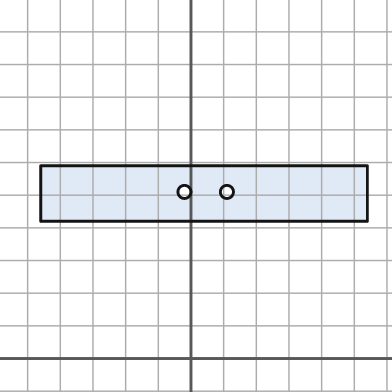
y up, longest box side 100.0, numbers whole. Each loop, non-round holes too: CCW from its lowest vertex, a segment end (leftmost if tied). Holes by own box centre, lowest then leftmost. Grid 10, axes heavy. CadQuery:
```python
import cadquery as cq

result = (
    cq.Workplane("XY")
    .moveTo(-46.0, 42.0)
    .lineTo(54.0, 42.0)
    .lineTo(54.0, 59.0)
    .lineTo(-46.0, 59.0)
    .close()
    .moveTo(-2.0, 51.0)
    .circle(2.0)
    .moveTo(11.0, 51.0)
    .circle(2.0)
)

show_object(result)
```